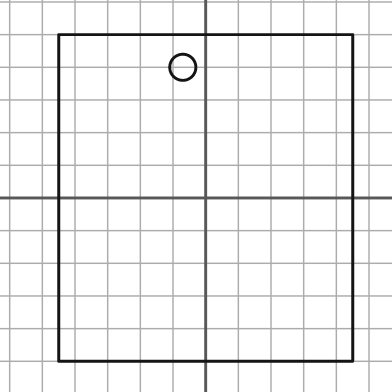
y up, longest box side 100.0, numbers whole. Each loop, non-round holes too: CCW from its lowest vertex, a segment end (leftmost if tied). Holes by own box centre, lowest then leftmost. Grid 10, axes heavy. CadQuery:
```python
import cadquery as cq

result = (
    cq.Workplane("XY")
    .moveTo(-45.0, -50.0)
    .lineTo(45.0, -50.0)
    .lineTo(45.0, 50.0)
    .lineTo(-45.0, 50.0)
    .close()
    .moveTo(-7.0, 40.0)
    .circle(4.0)
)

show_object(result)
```